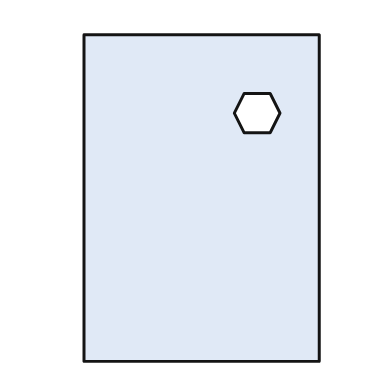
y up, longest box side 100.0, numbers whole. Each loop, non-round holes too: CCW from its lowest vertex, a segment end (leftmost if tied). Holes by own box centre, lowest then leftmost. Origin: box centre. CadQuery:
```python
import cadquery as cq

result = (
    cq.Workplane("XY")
    .moveTo(-36.0, -50.0)
    .lineTo(36.0, -50.0)
    .lineTo(36.0, 50.0)
    .lineTo(-36.0, 50.0)
    .close()
    .moveTo(13.0, 20.0)
    .lineTo(21.0, 20.0)
    .lineTo(24.0, 26.0)
    .lineTo(21.0, 32.0)
    .lineTo(13.0, 32.0)
    .lineTo(10.0, 26.0)
    .close()
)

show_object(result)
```